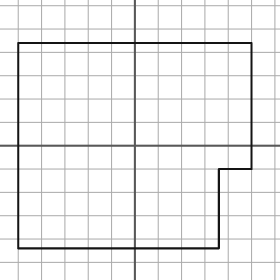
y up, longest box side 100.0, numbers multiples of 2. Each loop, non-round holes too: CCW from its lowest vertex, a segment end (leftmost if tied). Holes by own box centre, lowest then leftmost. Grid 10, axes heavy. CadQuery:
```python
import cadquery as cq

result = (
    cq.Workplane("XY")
    .moveTo(-50.0, -44.0)
    .lineTo(36.0, -44.0)
    .lineTo(36.0, -10.0)
    .lineTo(50.0, -10.0)
    .lineTo(50.0, 44.0)
    .lineTo(-50.0, 44.0)
    .close()
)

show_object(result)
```